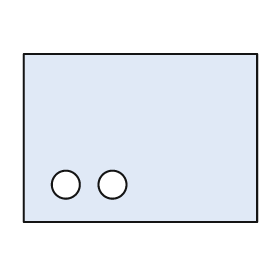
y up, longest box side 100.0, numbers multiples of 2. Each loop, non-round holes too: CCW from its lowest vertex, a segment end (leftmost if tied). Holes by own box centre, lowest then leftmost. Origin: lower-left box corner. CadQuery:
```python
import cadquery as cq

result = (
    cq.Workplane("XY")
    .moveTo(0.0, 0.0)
    .lineTo(100.0, 0.0)
    .lineTo(100.0, 72.0)
    .lineTo(0.0, 72.0)
    .close()
    .moveTo(18.0, 16.0)
    .circle(6.0)
    .moveTo(38.0, 16.0)
    .circle(6.0)
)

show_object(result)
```